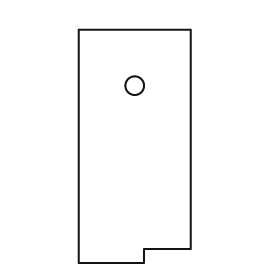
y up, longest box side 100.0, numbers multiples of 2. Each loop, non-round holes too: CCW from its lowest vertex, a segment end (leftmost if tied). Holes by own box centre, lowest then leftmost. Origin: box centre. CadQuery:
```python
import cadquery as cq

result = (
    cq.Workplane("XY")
    .moveTo(-24.0, -50.0)
    .lineTo(4.0, -50.0)
    .lineTo(4.0, -44.0)
    .lineTo(24.0, -44.0)
    .lineTo(24.0, 50.0)
    .lineTo(-24.0, 50.0)
    .close()
    .moveTo(0.0, 26.0)
    .circle(4.0)
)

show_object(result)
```